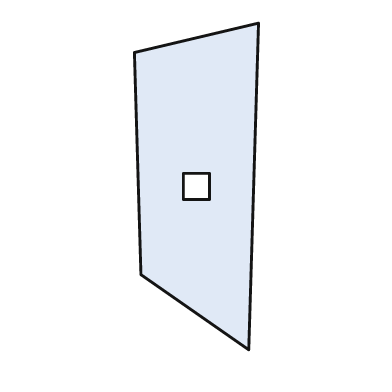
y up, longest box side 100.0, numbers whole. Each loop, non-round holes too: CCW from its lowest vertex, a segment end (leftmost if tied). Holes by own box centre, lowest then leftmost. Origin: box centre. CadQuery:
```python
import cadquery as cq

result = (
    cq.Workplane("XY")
    .moveTo(16.0, -50.0)
    .lineTo(19.0, 50.0)
    .lineTo(-19.0, 41.0)
    .lineTo(-17.0, -27.0)
    .close()
    .moveTo(-4.0, -4.0)
    .lineTo(4.0, -4.0)
    .lineTo(4.0, 4.0)
    .lineTo(-4.0, 4.0)
    .close()
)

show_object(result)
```